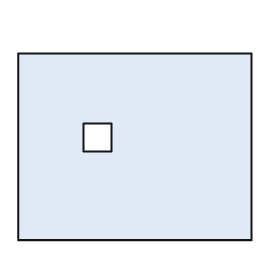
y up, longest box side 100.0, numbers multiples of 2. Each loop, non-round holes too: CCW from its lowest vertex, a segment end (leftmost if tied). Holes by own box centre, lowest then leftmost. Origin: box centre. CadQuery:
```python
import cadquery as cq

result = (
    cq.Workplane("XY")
    .moveTo(-50.0, -40.0)
    .lineTo(50.0, -40.0)
    .lineTo(50.0, 40.0)
    .lineTo(-50.0, 40.0)
    .close()
    .moveTo(-22.0, -2.0)
    .lineTo(-10.0, -2.0)
    .lineTo(-10.0, 10.0)
    .lineTo(-22.0, 10.0)
    .close()
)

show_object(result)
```